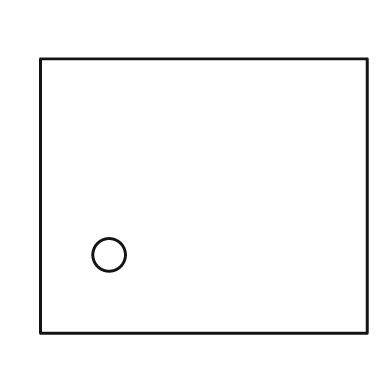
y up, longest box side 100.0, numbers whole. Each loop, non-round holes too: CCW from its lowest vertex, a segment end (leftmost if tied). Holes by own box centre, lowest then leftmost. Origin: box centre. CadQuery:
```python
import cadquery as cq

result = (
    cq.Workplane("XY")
    .moveTo(-50.0, -42.0)
    .lineTo(50.0, -42.0)
    .lineTo(50.0, 42.0)
    .lineTo(-50.0, 42.0)
    .close()
    .moveTo(-29.0, -18.0)
    .circle(5.0)
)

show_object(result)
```